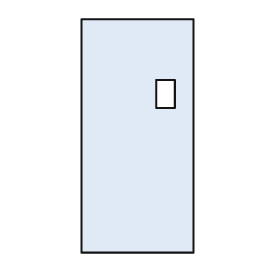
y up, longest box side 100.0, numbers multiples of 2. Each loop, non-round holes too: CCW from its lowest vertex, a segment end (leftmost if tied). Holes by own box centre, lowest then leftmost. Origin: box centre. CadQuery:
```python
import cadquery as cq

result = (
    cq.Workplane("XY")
    .moveTo(-24.0, -50.0)
    .lineTo(24.0, -50.0)
    .lineTo(24.0, 50.0)
    .lineTo(-24.0, 50.0)
    .close()
    .moveTo(8.0, 12.0)
    .lineTo(16.0, 12.0)
    .lineTo(16.0, 24.0)
    .lineTo(8.0, 24.0)
    .close()
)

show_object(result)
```